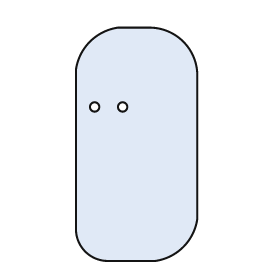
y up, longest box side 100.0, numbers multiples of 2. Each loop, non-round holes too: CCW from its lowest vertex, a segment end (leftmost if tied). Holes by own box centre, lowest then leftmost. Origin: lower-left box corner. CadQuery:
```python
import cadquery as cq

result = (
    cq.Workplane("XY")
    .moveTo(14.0, 0.0)
    .lineTo(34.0, 0.0)
    .threePointArc((46.0, 6.0), (52.0, 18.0))
    .lineTo(52.0, 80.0)
    .threePointArc((46.0, 94.0), (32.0, 100.0))
    .lineTo(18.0, 100.0)
    .threePointArc((6.0, 94.0), (0.0, 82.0))
    .lineTo(0.0, 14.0)
    .threePointArc((4.0, 4.0), (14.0, 0.0))
    .close()
    .moveTo(8.0, 66.0)
    .circle(2.0)
    .moveTo(20.0, 66.0)
    .circle(2.0)
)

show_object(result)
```